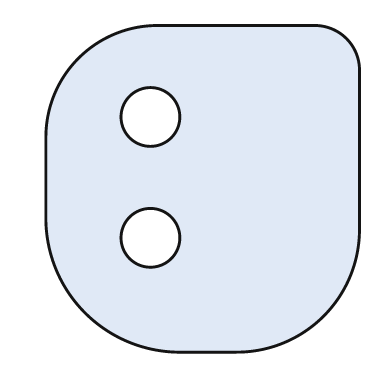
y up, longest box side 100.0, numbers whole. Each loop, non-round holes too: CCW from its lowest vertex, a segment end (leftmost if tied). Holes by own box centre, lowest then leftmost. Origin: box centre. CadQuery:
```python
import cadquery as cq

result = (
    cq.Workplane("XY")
    .moveTo(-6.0, -50.0)
    .lineTo(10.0, -50.0)
    .threePointArc((37.0, -39.0), (48.0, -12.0))
    .lineTo(48.0, 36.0)
    .threePointArc((44.0, 46.0), (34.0, 50.0))
    .lineTo(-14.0, 50.0)
    .threePointArc((-38.0, 40.0), (-48.0, 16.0))
    .lineTo(-48.0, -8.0)
    .threePointArc((-36.0, -38.0), (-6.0, -50.0))
    .close()
    .moveTo(-16.0, -15.0)
    .circle(9.0)
    .moveTo(-16.0, 22.0)
    .circle(9.0)
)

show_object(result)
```